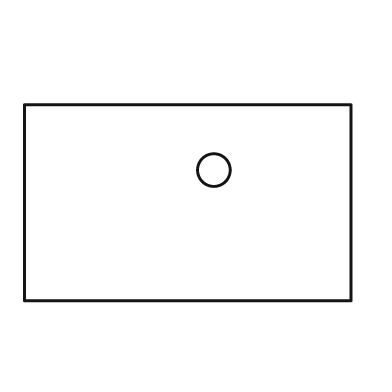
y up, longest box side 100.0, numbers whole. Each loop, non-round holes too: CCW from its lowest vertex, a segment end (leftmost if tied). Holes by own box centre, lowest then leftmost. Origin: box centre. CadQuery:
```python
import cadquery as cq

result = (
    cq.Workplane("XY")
    .moveTo(-50.0, -30.0)
    .lineTo(50.0, -30.0)
    .lineTo(50.0, 30.0)
    .lineTo(-50.0, 30.0)
    .close()
    .moveTo(8.0, 10.0)
    .circle(5.0)
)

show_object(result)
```